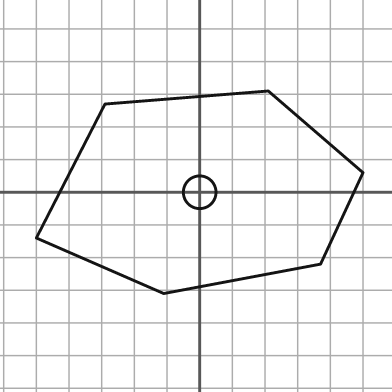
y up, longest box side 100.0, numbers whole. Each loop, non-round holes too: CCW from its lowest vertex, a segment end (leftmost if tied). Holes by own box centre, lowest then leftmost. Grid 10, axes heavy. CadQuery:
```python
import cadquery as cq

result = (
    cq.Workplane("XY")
    .moveTo(-11.0, -31.0)
    .lineTo(37.0, -22.0)
    .lineTo(50.0, 6.0)
    .lineTo(21.0, 31.0)
    .lineTo(-29.0, 27.0)
    .lineTo(-50.0, -14.0)
    .close()
    .moveTo(0.0, 0.0)
    .circle(5.0)
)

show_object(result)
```